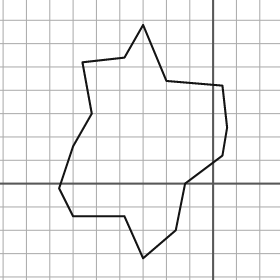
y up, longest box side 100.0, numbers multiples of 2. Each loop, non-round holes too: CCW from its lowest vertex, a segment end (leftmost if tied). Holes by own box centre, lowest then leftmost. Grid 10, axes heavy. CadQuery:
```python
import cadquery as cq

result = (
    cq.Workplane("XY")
    .moveTo(-30.0, -32.0)
    .lineTo(-16.0, -20.0)
    .lineTo(-12.0, 0.0)
    .lineTo(4.0, 12.0)
    .lineTo(6.0, 24.0)
    .lineTo(4.0, 42.0)
    .lineTo(-20.0, 44.0)
    .lineTo(-30.0, 68.0)
    .lineTo(-38.0, 54.0)
    .lineTo(-56.0, 52.0)
    .lineTo(-52.0, 30.0)
    .lineTo(-60.0, 16.0)
    .lineTo(-66.0, -2.0)
    .lineTo(-60.0, -14.0)
    .lineTo(-38.0, -14.0)
    .close()
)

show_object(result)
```